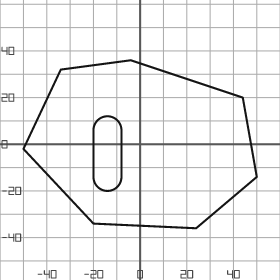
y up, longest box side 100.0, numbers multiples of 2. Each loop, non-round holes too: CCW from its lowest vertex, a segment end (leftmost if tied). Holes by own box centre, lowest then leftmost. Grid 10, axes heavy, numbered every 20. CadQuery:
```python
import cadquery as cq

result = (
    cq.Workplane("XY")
    .moveTo(24.0, -36.0)
    .lineTo(50.0, -14.0)
    .lineTo(44.0, 20.0)
    .lineTo(-4.0, 36.0)
    .lineTo(-34.0, 32.0)
    .lineTo(-50.0, -2.0)
    .lineTo(-20.0, -34.0)
    .close()
    .moveTo(-20.0, -14.0)
    .threePointArc((-14.0, -20.0), (-8.0, -14.0))
    .lineTo(-8.0, 6.0)
    .threePointArc((-14.0, 12.0), (-20.0, 6.0))
    .close()
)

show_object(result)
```